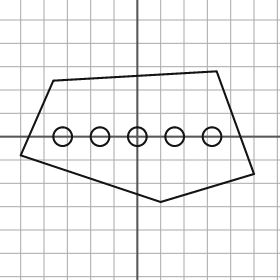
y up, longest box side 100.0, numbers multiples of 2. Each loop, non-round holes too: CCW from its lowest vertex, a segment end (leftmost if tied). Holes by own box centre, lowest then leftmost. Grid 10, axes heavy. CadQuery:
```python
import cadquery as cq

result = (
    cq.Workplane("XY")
    .moveTo(10.0, -28.0)
    .lineTo(50.0, -16.0)
    .lineTo(34.0, 28.0)
    .lineTo(-36.0, 24.0)
    .lineTo(-50.0, -8.0)
    .close()
    .moveTo(-32.0, 0.0)
    .circle(4.0)
    .moveTo(-16.0, 0.0)
    .circle(4.0)
    .moveTo(0.0, 0.0)
    .circle(4.0)
    .moveTo(16.0, 0.0)
    .circle(4.0)
    .moveTo(32.0, 0.0)
    .circle(4.0)
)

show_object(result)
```